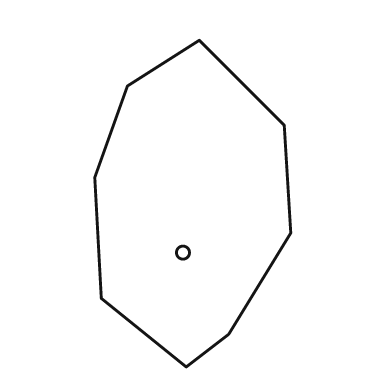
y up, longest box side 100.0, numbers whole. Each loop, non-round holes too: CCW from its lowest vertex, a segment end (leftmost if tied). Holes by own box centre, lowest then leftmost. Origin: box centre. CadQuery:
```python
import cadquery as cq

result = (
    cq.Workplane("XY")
    .moveTo(-2.0, -50.0)
    .lineTo(11.0, -40.0)
    .lineTo(30.0, -9.0)
    .lineTo(28.0, 24.0)
    .lineTo(2.0, 50.0)
    .lineTo(-20.0, 36.0)
    .lineTo(-30.0, 8.0)
    .lineTo(-28.0, -29.0)
    .close()
    .moveTo(-3.0, -15.0)
    .circle(2.0)
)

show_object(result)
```